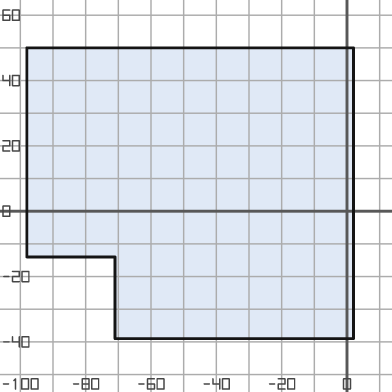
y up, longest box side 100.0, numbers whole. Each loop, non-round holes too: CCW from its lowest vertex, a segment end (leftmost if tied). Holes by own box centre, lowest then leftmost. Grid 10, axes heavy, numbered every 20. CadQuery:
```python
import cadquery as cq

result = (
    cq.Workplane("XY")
    .moveTo(-71.0, -39.0)
    .lineTo(2.0, -39.0)
    .lineTo(2.0, 50.0)
    .lineTo(-98.0, 50.0)
    .lineTo(-98.0, -14.0)
    .lineTo(-71.0, -14.0)
    .close()
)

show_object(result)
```